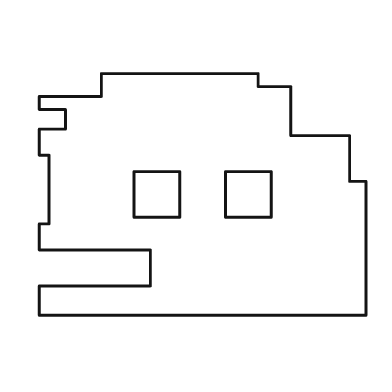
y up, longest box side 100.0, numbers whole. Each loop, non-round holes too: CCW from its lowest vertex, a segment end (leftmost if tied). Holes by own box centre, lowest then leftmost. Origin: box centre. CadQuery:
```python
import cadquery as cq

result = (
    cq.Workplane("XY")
    .moveTo(-50.0, -37.0)
    .lineTo(50.0, -37.0)
    .lineTo(50.0, 4.0)
    .lineTo(45.0, 4.0)
    .lineTo(45.0, 18.0)
    .lineTo(27.0, 18.0)
    .lineTo(27.0, 33.0)
    .lineTo(17.0, 33.0)
    .lineTo(17.0, 37.0)
    .lineTo(-31.0, 37.0)
    .lineTo(-31.0, 30.0)
    .lineTo(-50.0, 30.0)
    .lineTo(-50.0, 26.0)
    .lineTo(-42.0, 26.0)
    .lineTo(-42.0, 20.0)
    .lineTo(-50.0, 20.0)
    .lineTo(-50.0, 12.0)
    .lineTo(-47.0, 12.0)
    .lineTo(-47.0, -9.0)
    .lineTo(-50.0, -9.0)
    .lineTo(-50.0, -17.0)
    .lineTo(-16.0, -17.0)
    .lineTo(-16.0, -28.0)
    .lineTo(-50.0, -28.0)
    .close()
    .moveTo(-21.0, -7.0)
    .lineTo(-7.0, -7.0)
    .lineTo(-7.0, 7.0)
    .lineTo(-21.0, 7.0)
    .close()
    .moveTo(7.0, -7.0)
    .lineTo(21.0, -7.0)
    .lineTo(21.0, 7.0)
    .lineTo(7.0, 7.0)
    .close()
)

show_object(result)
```